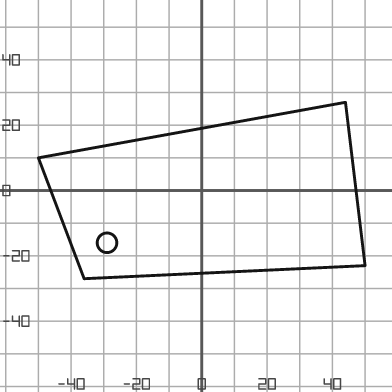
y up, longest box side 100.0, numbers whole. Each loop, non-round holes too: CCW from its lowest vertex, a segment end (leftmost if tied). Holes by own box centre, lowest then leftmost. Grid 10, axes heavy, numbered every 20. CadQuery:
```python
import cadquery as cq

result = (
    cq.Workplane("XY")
    .moveTo(-36.0, -27.0)
    .lineTo(50.0, -23.0)
    .lineTo(44.0, 27.0)
    .lineTo(-50.0, 10.0)
    .close()
    .moveTo(-29.0, -16.0)
    .circle(3.0)
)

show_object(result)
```